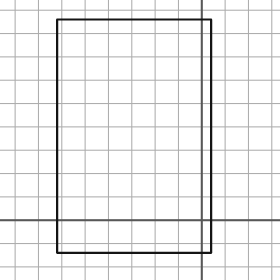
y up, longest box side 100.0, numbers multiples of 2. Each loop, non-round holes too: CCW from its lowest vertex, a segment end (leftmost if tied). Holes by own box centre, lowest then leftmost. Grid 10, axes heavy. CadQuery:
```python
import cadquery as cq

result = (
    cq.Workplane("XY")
    .moveTo(-62.0, -14.0)
    .lineTo(4.0, -14.0)
    .lineTo(4.0, 86.0)
    .lineTo(-62.0, 86.0)
    .close()
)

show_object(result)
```